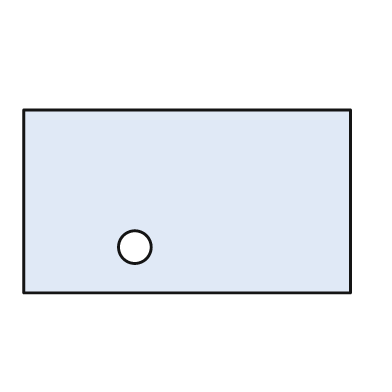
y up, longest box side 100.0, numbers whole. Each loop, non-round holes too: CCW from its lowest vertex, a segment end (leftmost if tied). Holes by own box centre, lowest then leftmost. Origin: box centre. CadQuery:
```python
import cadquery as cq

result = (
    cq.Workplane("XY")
    .moveTo(-50.0, -28.0)
    .lineTo(50.0, -28.0)
    .lineTo(50.0, 28.0)
    .lineTo(-50.0, 28.0)
    .close()
    .moveTo(-16.0, -14.0)
    .circle(5.0)
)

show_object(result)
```